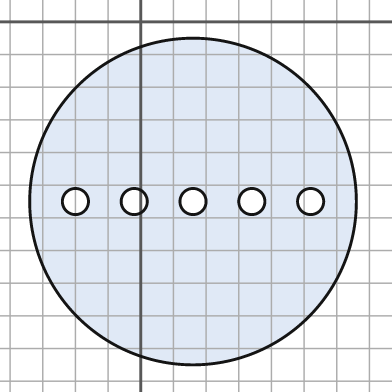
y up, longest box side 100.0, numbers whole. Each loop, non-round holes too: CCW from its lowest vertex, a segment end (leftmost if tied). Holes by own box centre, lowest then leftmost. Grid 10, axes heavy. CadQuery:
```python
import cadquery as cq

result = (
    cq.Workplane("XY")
    .moveTo(16.0, -55.0)
    .circle(50.0)
    .moveTo(-20.0, -55.0)
    .circle(4.0)
    .moveTo(-2.0, -55.0)
    .circle(4.0)
    .moveTo(16.0, -55.0)
    .circle(4.0)
    .moveTo(34.0, -55.0)
    .circle(4.0)
    .moveTo(52.0, -55.0)
    .circle(4.0)
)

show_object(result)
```